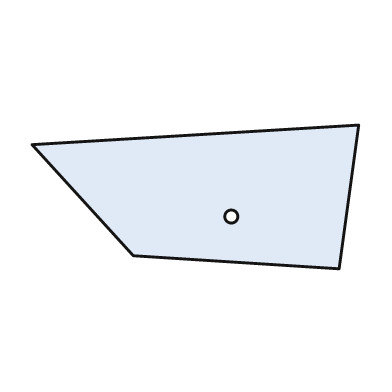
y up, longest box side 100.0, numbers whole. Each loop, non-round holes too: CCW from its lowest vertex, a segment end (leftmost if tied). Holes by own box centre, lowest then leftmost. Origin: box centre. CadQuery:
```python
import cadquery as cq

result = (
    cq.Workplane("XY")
    .moveTo(44.0, -22.0)
    .lineTo(50.0, 22.0)
    .lineTo(-50.0, 16.0)
    .lineTo(-19.0, -18.0)
    .close()
    .moveTo(11.0, -6.0)
    .circle(2.0)
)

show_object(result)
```